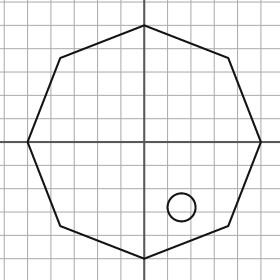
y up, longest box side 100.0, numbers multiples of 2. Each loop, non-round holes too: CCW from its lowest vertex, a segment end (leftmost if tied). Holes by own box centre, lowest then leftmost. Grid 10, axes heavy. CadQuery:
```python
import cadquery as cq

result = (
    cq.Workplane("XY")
    .moveTo(0.0, -50.0)
    .lineTo(36.0, -36.0)
    .lineTo(50.0, 0.0)
    .lineTo(36.0, 36.0)
    .lineTo(0.0, 50.0)
    .lineTo(-36.0, 36.0)
    .lineTo(-50.0, 0.0)
    .lineTo(-36.0, -36.0)
    .close()
    .moveTo(16.0, -28.0)
    .circle(6.0)
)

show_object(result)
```